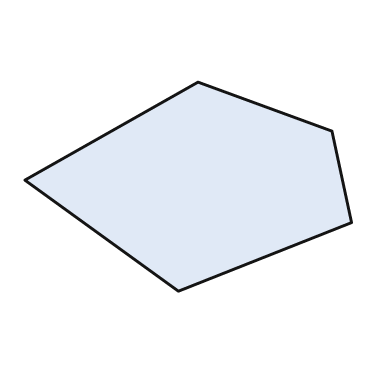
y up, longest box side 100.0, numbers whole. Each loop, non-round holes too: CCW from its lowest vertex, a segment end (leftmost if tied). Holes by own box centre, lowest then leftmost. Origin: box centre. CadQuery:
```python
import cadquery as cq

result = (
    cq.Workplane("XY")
    .moveTo(-3.0, -32.0)
    .lineTo(50.0, -11.0)
    .lineTo(44.0, 17.0)
    .lineTo(3.0, 32.0)
    .lineTo(-50.0, 2.0)
    .close()
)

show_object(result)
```